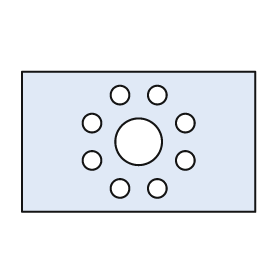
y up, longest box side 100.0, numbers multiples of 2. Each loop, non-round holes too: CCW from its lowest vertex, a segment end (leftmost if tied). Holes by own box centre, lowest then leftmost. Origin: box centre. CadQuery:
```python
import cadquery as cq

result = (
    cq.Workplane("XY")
    .moveTo(-50.0, -30.0)
    .lineTo(50.0, -30.0)
    .lineTo(50.0, 30.0)
    .lineTo(-50.0, 30.0)
    .close()
    .moveTo(-8.0, -20.0)
    .circle(4.0)
    .moveTo(8.0, -20.0)
    .circle(4.0)
    .moveTo(-20.0, -8.0)
    .circle(4.0)
    .moveTo(20.0, -8.0)
    .circle(4.0)
    .moveTo(0.0, 0.0)
    .circle(10.0)
    .moveTo(-20.0, 8.0)
    .circle(4.0)
    .moveTo(20.0, 8.0)
    .circle(4.0)
    .moveTo(-8.0, 20.0)
    .circle(4.0)
    .moveTo(8.0, 20.0)
    .circle(4.0)
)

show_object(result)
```